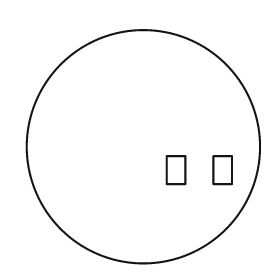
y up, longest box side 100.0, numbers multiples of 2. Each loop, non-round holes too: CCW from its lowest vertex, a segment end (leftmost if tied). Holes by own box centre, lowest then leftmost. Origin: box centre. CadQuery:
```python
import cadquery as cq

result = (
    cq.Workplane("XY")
    .moveTo(0.0, 0.0)
    .circle(50.0)
    .moveTo(10.0, -16.0)
    .lineTo(18.0, -16.0)
    .lineTo(18.0, -4.0)
    .lineTo(10.0, -4.0)
    .close()
    .moveTo(30.0, -16.0)
    .lineTo(38.0, -16.0)
    .lineTo(38.0, -4.0)
    .lineTo(30.0, -4.0)
    .close()
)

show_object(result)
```